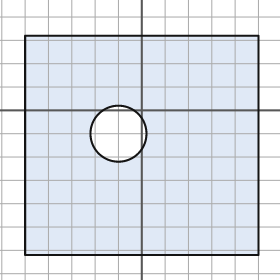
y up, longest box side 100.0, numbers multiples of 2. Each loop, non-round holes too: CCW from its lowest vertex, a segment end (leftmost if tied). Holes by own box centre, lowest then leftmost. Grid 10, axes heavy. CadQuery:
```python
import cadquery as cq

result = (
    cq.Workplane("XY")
    .moveTo(-50.0, -62.0)
    .lineTo(50.0, -62.0)
    .lineTo(50.0, 32.0)
    .lineTo(-50.0, 32.0)
    .close()
    .moveTo(-10.0, -10.0)
    .circle(12.0)
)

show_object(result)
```